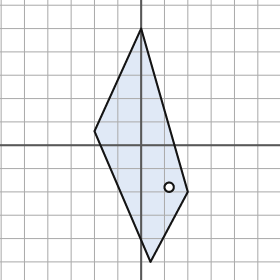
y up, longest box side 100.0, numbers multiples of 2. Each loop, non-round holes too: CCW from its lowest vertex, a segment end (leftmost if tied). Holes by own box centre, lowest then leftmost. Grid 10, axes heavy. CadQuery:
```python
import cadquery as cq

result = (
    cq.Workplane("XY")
    .moveTo(4.0, -50.0)
    .lineTo(20.0, -20.0)
    .lineTo(0.0, 50.0)
    .lineTo(-20.0, 6.0)
    .close()
    .moveTo(12.0, -18.0)
    .circle(2.0)
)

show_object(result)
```